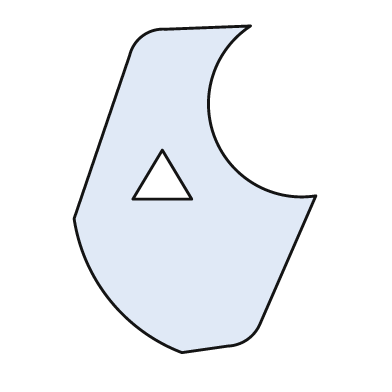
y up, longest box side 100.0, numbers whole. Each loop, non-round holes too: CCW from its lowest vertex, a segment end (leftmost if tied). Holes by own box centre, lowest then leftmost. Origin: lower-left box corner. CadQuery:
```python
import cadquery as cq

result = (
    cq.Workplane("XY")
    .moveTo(33.0, 0.0)
    .lineTo(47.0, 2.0)
    .threePointArc((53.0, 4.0), (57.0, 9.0))
    .lineTo(74.0, 48.0)
    .threePointArc((43.0, 66.0), (54.0, 100.0))
    .lineTo(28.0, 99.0)
    .threePointArc((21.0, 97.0), (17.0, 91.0))
    .lineTo(0.0, 41.0)
    .threePointArc((11.0, 16.0), (33.0, 0.0))
    .close()
    .moveTo(18.0, 47.0)
    .lineTo(36.0, 47.0)
    .lineTo(27.0, 62.0)
    .close()
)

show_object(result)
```